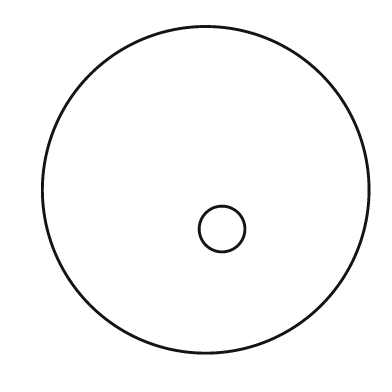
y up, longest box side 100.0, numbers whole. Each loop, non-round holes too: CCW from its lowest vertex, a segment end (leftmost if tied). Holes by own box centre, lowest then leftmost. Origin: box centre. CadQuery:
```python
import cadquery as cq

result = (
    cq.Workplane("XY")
    .moveTo(0.0, 0.0)
    .circle(50.0)
    .moveTo(5.0, -12.0)
    .circle(7.0)
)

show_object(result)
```